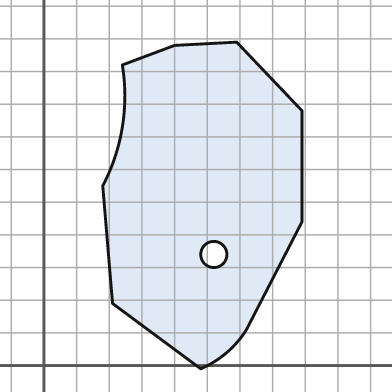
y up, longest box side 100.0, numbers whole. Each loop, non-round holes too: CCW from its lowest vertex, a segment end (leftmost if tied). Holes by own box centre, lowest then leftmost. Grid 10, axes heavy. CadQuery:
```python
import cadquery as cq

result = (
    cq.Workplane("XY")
    .moveTo(48.0, -1.0)
    .threePointArc((56.0, 4.0), (62.0, 11.0))
    .lineTo(79.0, 44.0)
    .lineTo(79.0, 78.0)
    .lineTo(59.0, 99.0)
    .lineTo(40.0, 98.0)
    .lineTo(24.0, 92.0)
    .threePointArc((24.0, 73.0), (18.0, 55.0))
    .lineTo(21.0, 19.0)
    .close()
    .moveTo(52.0, 34.0)
    .circle(4.0)
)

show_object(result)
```